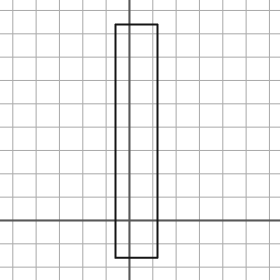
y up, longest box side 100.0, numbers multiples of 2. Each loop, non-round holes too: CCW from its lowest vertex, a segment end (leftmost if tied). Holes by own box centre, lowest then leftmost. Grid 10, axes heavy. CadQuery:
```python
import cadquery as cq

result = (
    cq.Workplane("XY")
    .moveTo(-6.0, -16.0)
    .lineTo(12.0, -16.0)
    .lineTo(12.0, 84.0)
    .lineTo(-6.0, 84.0)
    .close()
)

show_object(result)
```